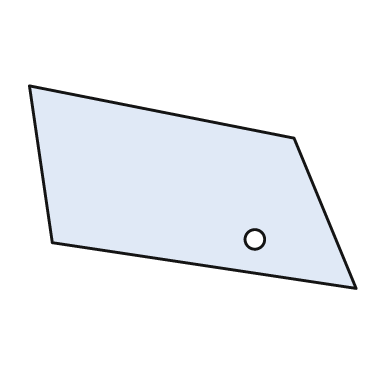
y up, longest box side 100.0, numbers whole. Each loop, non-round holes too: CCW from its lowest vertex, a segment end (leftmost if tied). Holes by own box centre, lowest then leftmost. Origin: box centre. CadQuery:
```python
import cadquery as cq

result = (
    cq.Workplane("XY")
    .moveTo(50.0, -31.0)
    .lineTo(31.0, 15.0)
    .lineTo(-50.0, 31.0)
    .lineTo(-43.0, -17.0)
    .close()
    .moveTo(19.0, -16.0)
    .circle(3.0)
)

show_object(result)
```